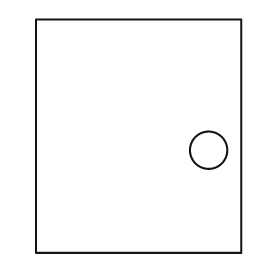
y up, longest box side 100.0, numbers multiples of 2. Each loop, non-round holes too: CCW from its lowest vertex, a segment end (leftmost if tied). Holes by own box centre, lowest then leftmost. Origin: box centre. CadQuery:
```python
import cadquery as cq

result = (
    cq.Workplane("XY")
    .moveTo(-44.0, -50.0)
    .lineTo(44.0, -50.0)
    .lineTo(44.0, 50.0)
    .lineTo(-44.0, 50.0)
    .close()
    .moveTo(30.0, -6.0)
    .circle(8.0)
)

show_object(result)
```